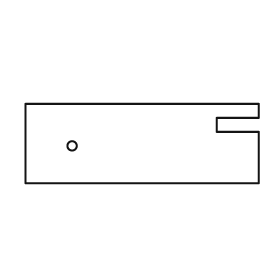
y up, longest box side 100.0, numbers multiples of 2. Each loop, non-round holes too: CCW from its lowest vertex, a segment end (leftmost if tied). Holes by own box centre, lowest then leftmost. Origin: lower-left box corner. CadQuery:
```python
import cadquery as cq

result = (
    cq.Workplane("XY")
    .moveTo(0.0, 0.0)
    .lineTo(100.0, 0.0)
    .lineTo(100.0, 22.0)
    .lineTo(82.0, 22.0)
    .lineTo(82.0, 28.0)
    .lineTo(100.0, 28.0)
    .lineTo(100.0, 34.0)
    .lineTo(0.0, 34.0)
    .close()
    .moveTo(20.0, 16.0)
    .circle(2.0)
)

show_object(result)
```